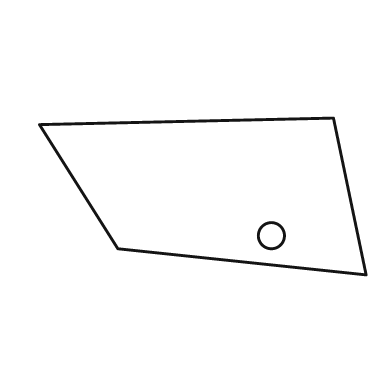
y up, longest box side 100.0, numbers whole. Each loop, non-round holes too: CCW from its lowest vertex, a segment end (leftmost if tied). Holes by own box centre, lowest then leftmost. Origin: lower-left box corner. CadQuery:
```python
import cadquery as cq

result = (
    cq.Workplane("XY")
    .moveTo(100.0, 0.0)
    .lineTo(90.0, 48.0)
    .lineTo(0.0, 46.0)
    .lineTo(24.0, 8.0)
    .close()
    .moveTo(71.0, 12.0)
    .circle(4.0)
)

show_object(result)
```